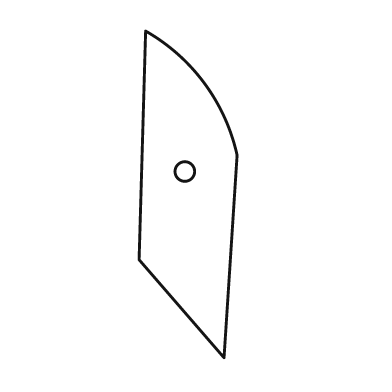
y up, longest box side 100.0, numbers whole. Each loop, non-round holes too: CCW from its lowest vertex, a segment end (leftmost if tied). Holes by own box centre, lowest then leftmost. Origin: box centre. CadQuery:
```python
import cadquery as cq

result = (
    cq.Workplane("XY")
    .moveTo(11.0, -50.0)
    .lineTo(15.0, 12.0)
    .threePointArc((5.0, 34.0), (-13.0, 50.0))
    .lineTo(-15.0, -20.0)
    .close()
    .moveTo(-1.0, 7.0)
    .circle(3.0)
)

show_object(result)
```